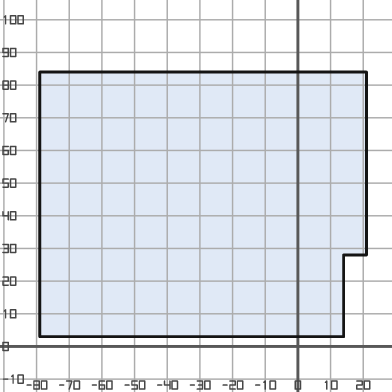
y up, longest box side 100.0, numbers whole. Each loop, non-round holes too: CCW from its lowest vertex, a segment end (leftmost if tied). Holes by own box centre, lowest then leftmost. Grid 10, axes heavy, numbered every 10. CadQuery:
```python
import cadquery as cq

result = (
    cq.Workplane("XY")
    .moveTo(-79.0, 3.0)
    .lineTo(14.0, 3.0)
    .lineTo(14.0, 28.0)
    .lineTo(21.0, 28.0)
    .lineTo(21.0, 84.0)
    .lineTo(-79.0, 84.0)
    .close()
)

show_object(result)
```